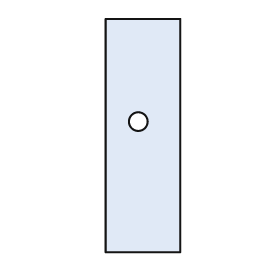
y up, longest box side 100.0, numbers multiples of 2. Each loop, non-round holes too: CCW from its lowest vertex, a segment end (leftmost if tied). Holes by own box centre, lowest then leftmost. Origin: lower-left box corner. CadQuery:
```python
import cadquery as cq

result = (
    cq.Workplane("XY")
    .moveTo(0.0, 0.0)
    .lineTo(32.0, 0.0)
    .lineTo(32.0, 100.0)
    .lineTo(0.0, 100.0)
    .close()
    .moveTo(14.0, 56.0)
    .circle(4.0)
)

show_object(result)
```